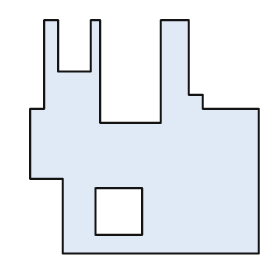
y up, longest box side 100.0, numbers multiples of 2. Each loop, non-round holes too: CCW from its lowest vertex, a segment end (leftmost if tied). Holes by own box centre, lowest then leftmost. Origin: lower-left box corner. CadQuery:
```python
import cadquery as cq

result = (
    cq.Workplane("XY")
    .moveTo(14.0, 0.0)
    .lineTo(98.0, 0.0)
    .lineTo(98.0, 62.0)
    .lineTo(74.0, 62.0)
    .lineTo(74.0, 68.0)
    .lineTo(68.0, 68.0)
    .lineTo(68.0, 100.0)
    .lineTo(56.0, 100.0)
    .lineTo(56.0, 56.0)
    .lineTo(30.0, 56.0)
    .lineTo(30.0, 100.0)
    .lineTo(26.0, 100.0)
    .lineTo(26.0, 78.0)
    .lineTo(12.0, 78.0)
    .lineTo(12.0, 100.0)
    .lineTo(6.0, 100.0)
    .lineTo(6.0, 62.0)
    .lineTo(0.0, 62.0)
    .lineTo(0.0, 32.0)
    .lineTo(14.0, 32.0)
    .close()
    .moveTo(28.0, 8.0)
    .lineTo(48.0, 8.0)
    .lineTo(48.0, 28.0)
    .lineTo(28.0, 28.0)
    .close()
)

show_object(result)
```